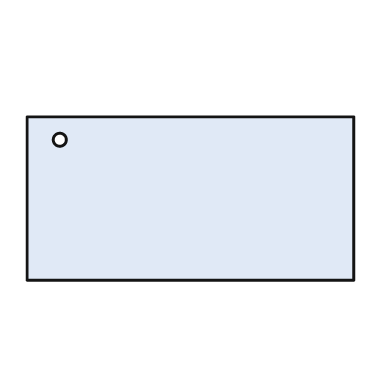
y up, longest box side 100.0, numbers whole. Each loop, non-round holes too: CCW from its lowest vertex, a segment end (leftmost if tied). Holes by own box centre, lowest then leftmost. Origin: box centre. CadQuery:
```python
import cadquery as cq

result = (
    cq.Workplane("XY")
    .moveTo(-50.0, -25.0)
    .lineTo(50.0, -25.0)
    .lineTo(50.0, 25.0)
    .lineTo(-50.0, 25.0)
    .close()
    .moveTo(-40.0, 18.0)
    .circle(2.0)
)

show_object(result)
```